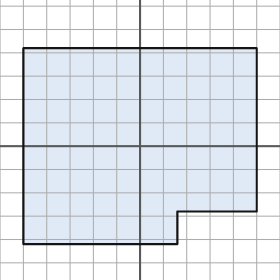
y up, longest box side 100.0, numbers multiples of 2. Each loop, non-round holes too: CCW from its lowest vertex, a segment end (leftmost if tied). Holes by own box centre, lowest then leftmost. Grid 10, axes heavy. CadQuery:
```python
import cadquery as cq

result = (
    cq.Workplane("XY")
    .moveTo(-50.0, -42.0)
    .lineTo(16.0, -42.0)
    .lineTo(16.0, -28.0)
    .lineTo(50.0, -28.0)
    .lineTo(50.0, 42.0)
    .lineTo(-50.0, 42.0)
    .close()
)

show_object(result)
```